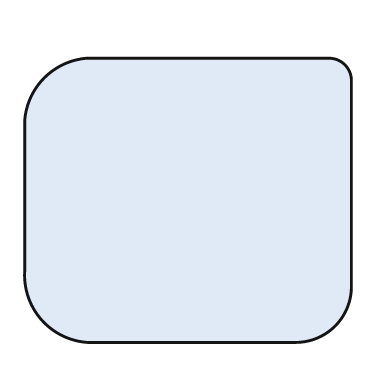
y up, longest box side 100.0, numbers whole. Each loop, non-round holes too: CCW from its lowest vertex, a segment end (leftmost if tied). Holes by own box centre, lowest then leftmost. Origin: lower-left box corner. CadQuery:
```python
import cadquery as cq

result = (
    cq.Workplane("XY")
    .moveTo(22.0, 0.0)
    .lineTo(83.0, 0.0)
    .threePointArc((95.0, 5.0), (100.0, 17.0))
    .lineTo(100.0, 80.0)
    .threePointArc((98.0, 85.0), (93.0, 87.0))
    .lineTo(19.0, 87.0)
    .threePointArc((6.0, 81.0), (0.0, 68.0))
    .lineTo(0.0, 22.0)
    .threePointArc((6.0, 6.0), (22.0, 0.0))
    .close()
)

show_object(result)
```